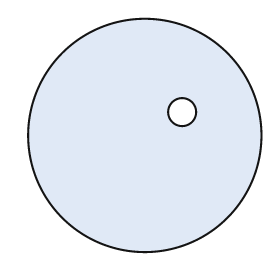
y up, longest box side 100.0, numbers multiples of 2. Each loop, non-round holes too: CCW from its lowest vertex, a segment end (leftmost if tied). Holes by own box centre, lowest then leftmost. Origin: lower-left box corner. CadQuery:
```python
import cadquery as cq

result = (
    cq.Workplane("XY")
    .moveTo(50.0, 50.0)
    .circle(50.0)
    .moveTo(66.0, 60.0)
    .circle(6.0)
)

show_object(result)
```